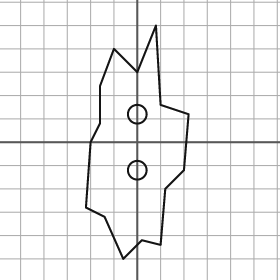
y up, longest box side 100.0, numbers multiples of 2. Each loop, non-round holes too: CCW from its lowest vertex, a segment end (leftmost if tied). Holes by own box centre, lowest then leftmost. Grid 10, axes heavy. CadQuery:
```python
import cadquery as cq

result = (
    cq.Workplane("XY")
    .moveTo(-6.0, -50.0)
    .lineTo(2.0, -42.0)
    .lineTo(10.0, -44.0)
    .lineTo(12.0, -20.0)
    .lineTo(20.0, -12.0)
    .lineTo(22.0, 12.0)
    .lineTo(10.0, 16.0)
    .lineTo(8.0, 50.0)
    .lineTo(0.0, 30.0)
    .lineTo(-10.0, 40.0)
    .lineTo(-16.0, 24.0)
    .lineTo(-16.0, 8.0)
    .lineTo(-20.0, 0.0)
    .lineTo(-22.0, -28.0)
    .lineTo(-14.0, -32.0)
    .close()
    .moveTo(0.0, -12.0)
    .circle(4.0)
    .moveTo(0.0, 12.0)
    .circle(4.0)
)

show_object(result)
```